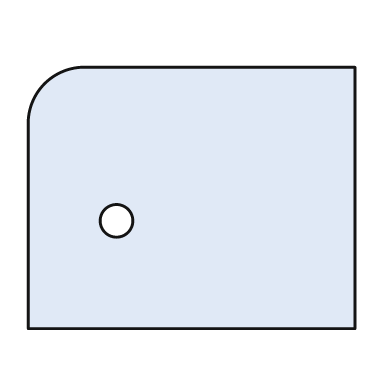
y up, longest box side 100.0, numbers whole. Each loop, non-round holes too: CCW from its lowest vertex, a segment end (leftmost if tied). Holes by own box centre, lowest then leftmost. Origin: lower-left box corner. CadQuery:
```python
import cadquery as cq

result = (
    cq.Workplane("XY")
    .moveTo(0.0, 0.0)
    .lineTo(100.0, 0.0)
    .lineTo(100.0, 80.0)
    .lineTo(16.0, 80.0)
    .threePointArc((5.0, 75.0), (0.0, 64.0))
    .close()
    .moveTo(27.0, 33.0)
    .circle(5.0)
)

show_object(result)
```